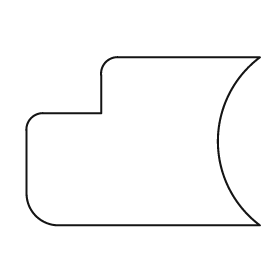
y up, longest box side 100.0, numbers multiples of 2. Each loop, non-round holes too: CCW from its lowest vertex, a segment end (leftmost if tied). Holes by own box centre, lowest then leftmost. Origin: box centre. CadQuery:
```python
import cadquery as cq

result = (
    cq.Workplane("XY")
    .moveTo(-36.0, -36.0)
    .lineTo(50.0, -36.0)
    .threePointArc((32.0, 0.0), (50.0, 36.0))
    .lineTo(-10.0, 36.0)
    .threePointArc((-16.0, 34.0), (-18.0, 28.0))
    .lineTo(-18.0, 12.0)
    .lineTo(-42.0, 12.0)
    .threePointArc((-48.0, 10.0), (-50.0, 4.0))
    .lineTo(-50.0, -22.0)
    .threePointArc((-46.0, -32.0), (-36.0, -36.0))
    .close()
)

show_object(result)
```